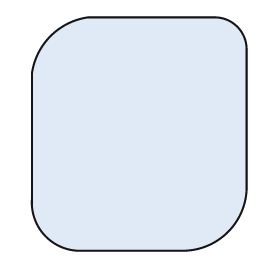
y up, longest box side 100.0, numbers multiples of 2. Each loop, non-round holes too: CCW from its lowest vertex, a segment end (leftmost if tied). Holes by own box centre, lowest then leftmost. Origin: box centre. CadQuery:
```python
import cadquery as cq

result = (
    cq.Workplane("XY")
    .moveTo(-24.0, -50.0)
    .lineTo(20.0, -50.0)
    .threePointArc((38.0, -42.0), (46.0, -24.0))
    .lineTo(46.0, 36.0)
    .threePointArc((42.0, 46.0), (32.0, 50.0))
    .lineTo(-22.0, 50.0)
    .threePointArc((-38.0, 42.0), (-46.0, 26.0))
    .lineTo(-46.0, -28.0)
    .threePointArc((-40.0, -44.0), (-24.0, -50.0))
    .close()
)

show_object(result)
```